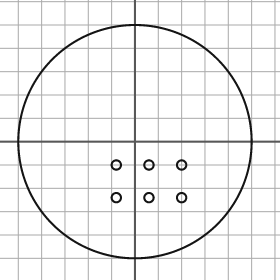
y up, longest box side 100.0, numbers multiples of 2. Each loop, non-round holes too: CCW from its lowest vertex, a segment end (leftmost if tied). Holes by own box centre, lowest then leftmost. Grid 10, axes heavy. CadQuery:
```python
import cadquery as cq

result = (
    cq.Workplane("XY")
    .moveTo(0.0, 0.0)
    .circle(50.0)
    .moveTo(-8.0, -24.0)
    .circle(2.0)
    .moveTo(6.0, -24.0)
    .circle(2.0)
    .moveTo(20.0, -24.0)
    .circle(2.0)
    .moveTo(-8.0, -10.0)
    .circle(2.0)
    .moveTo(6.0, -10.0)
    .circle(2.0)
    .moveTo(20.0, -10.0)
    .circle(2.0)
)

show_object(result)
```